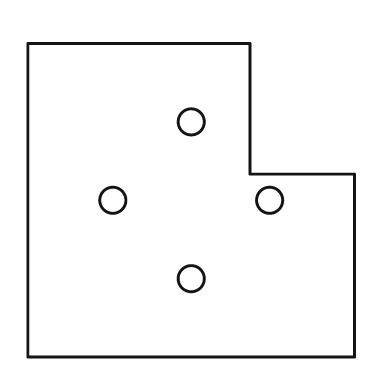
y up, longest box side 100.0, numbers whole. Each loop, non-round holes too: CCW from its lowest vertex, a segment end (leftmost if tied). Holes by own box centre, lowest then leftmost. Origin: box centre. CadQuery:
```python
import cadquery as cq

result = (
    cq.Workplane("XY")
    .moveTo(-50.0, -48.0)
    .lineTo(50.0, -48.0)
    .lineTo(50.0, 8.0)
    .lineTo(18.0, 8.0)
    .lineTo(18.0, 48.0)
    .lineTo(-50.0, 48.0)
    .close()
    .moveTo(0.0, -24.0)
    .circle(4.0)
    .moveTo(-24.0, 0.0)
    .circle(4.0)
    .moveTo(24.0, 0.0)
    .circle(4.0)
    .moveTo(0.0, 24.0)
    .circle(4.0)
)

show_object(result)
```